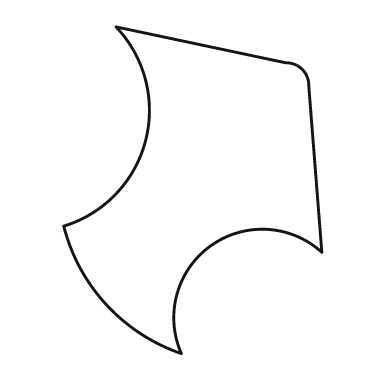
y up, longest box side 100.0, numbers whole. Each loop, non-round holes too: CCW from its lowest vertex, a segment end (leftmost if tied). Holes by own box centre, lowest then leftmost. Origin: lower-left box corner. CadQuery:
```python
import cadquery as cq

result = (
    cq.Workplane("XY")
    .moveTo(36.0, 0.0)
    .threePointArc((45.0, 33.0), (79.0, 31.0))
    .lineTo(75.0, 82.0)
    .threePointArc((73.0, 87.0), (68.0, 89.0))
    .lineTo(16.0, 100.0)
    .threePointArc((25.0, 65.0), (0.0, 39.0))
    .threePointArc((13.0, 15.0), (36.0, 0.0))
    .close()
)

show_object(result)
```